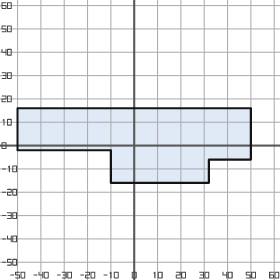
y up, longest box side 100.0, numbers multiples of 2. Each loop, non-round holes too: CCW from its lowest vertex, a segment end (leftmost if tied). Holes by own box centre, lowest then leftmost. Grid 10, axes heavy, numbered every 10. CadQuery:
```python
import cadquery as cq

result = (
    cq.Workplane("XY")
    .moveTo(-10.0, -16.0)
    .lineTo(32.0, -16.0)
    .lineTo(32.0, -6.0)
    .lineTo(50.0, -6.0)
    .lineTo(50.0, 16.0)
    .lineTo(-50.0, 16.0)
    .lineTo(-50.0, -2.0)
    .lineTo(-10.0, -2.0)
    .close()
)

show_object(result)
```